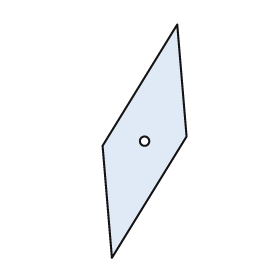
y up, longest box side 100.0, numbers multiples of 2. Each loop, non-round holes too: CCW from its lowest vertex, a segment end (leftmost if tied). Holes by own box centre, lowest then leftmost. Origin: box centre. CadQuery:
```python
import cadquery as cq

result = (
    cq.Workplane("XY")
    .moveTo(-14.0, -50.0)
    .lineTo(18.0, 2.0)
    .lineTo(14.0, 50.0)
    .lineTo(-18.0, -2.0)
    .close()
    .moveTo(0.0, 0.0)
    .circle(2.0)
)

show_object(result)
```